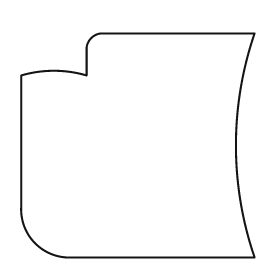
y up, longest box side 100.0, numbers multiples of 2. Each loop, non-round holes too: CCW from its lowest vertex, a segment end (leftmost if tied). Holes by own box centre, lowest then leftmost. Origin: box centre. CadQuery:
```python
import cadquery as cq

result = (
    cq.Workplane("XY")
    .moveTo(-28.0, -48.0)
    .lineTo(50.0, -48.0)
    .threePointArc((42.0, 0.0), (50.0, 48.0))
    .lineTo(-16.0, 48.0)
    .threePointArc((-20.0, 46.0), (-22.0, 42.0))
    .lineTo(-22.0, 30.0)
    .threePointArc((-36.0, 32.0), (-50.0, 30.0))
    .lineTo(-50.0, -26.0)
    .threePointArc((-44.0, -42.0), (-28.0, -48.0))
    .close()
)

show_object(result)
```